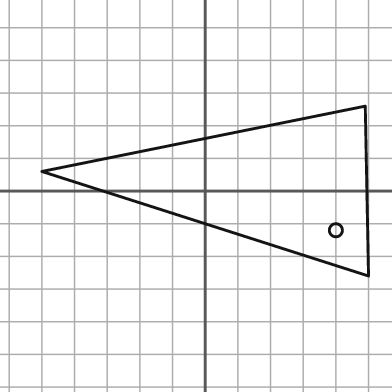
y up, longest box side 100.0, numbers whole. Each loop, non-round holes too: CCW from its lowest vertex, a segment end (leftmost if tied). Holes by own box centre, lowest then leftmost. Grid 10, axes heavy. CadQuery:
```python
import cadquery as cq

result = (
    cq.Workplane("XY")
    .moveTo(50.0, -26.0)
    .lineTo(49.0, 26.0)
    .lineTo(-50.0, 6.0)
    .close()
    .moveTo(40.0, -12.0)
    .circle(2.0)
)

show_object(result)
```